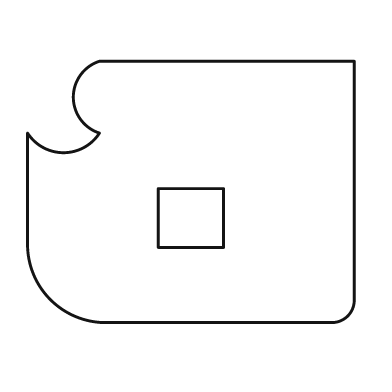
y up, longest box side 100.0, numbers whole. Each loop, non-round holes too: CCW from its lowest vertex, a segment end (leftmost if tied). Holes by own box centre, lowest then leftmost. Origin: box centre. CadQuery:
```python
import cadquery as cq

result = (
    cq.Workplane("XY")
    .moveTo(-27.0, -40.0)
    .lineTo(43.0, -40.0)
    .threePointArc((48.0, -38.0), (50.0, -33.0))
    .lineTo(50.0, 40.0)
    .lineTo(-28.0, 40.0)
    .threePointArc((-36.0, 29.0), (-28.0, 18.0))
    .threePointArc((-39.0, 12.0), (-50.0, 18.0))
    .lineTo(-50.0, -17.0)
    .threePointArc((-43.0, -33.0), (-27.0, -40.0))
    .close()
    .moveTo(-10.0, -17.0)
    .lineTo(10.0, -17.0)
    .lineTo(10.0, 1.0)
    .lineTo(-10.0, 1.0)
    .close()
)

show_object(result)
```